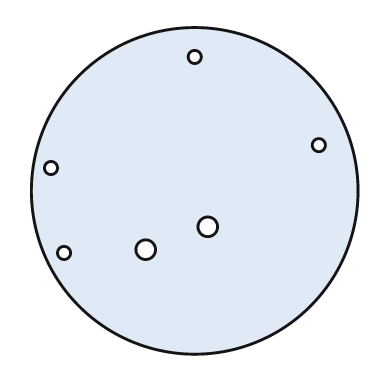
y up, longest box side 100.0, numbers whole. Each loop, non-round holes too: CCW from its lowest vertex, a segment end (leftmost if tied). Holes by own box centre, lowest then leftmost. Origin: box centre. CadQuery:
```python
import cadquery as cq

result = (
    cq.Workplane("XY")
    .moveTo(0.0, 0.0)
    .circle(50.0)
    .moveTo(-40.0, -19.0)
    .circle(2.0)
    .moveTo(-15.0, -18.0)
    .circle(3.0)
    .moveTo(4.0, -11.0)
    .circle(3.0)
    .moveTo(-44.0, 7.0)
    .circle(2.0)
    .moveTo(38.0, 14.0)
    .circle(2.0)
    .moveTo(0.0, 41.0)
    .circle(2.0)
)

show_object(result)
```